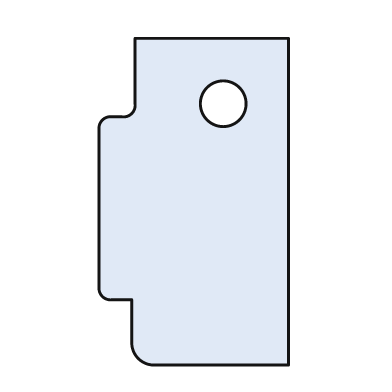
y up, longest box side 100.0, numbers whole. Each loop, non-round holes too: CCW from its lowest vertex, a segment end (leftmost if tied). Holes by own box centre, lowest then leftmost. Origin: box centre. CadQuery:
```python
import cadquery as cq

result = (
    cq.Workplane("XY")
    .moveTo(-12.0, -50.0)
    .lineTo(29.0, -50.0)
    .lineTo(29.0, 50.0)
    .lineTo(-18.0, 50.0)
    .lineTo(-18.0, 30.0)
    .threePointArc((-19.0, 27.0), (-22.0, 26.0))
    .lineTo(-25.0, 26.0)
    .threePointArc((-28.0, 25.0), (-29.0, 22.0))
    .lineTo(-29.0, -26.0)
    .threePointArc((-28.0, -29.0), (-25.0, -30.0))
    .lineTo(-19.0, -30.0)
    .lineTo(-19.0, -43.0)
    .threePointArc((-17.0, -48.0), (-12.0, -50.0))
    .close()
    .moveTo(9.0, 30.0)
    .circle(7.0)
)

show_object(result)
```